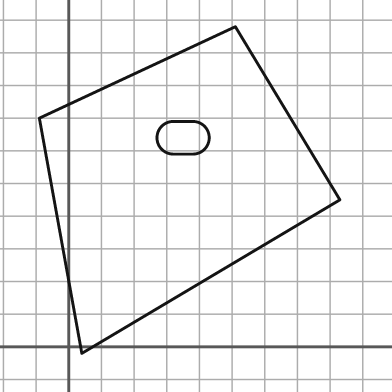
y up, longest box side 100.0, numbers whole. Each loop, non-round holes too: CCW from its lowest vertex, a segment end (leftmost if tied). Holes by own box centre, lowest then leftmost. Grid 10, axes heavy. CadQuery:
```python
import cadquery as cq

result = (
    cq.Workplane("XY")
    .moveTo(4.0, -2.0)
    .lineTo(83.0, 45.0)
    .lineTo(51.0, 98.0)
    .lineTo(-9.0, 70.0)
    .close()
    .moveTo(32.0, 59.0)
    .lineTo(38.0, 59.0)
    .threePointArc((43.0, 64.0), (38.0, 69.0))
    .lineTo(32.0, 69.0)
    .threePointArc((27.0, 64.0), (32.0, 59.0))
    .close()
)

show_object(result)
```